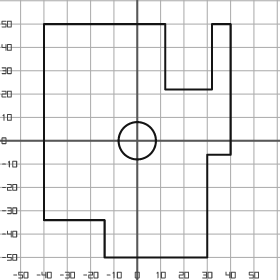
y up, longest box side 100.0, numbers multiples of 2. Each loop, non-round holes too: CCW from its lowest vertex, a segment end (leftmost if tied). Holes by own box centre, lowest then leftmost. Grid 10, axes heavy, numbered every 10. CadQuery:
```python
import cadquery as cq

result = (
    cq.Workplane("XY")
    .moveTo(-14.0, -50.0)
    .lineTo(30.0, -50.0)
    .lineTo(30.0, -6.0)
    .lineTo(40.0, -6.0)
    .lineTo(40.0, 50.0)
    .lineTo(32.0, 50.0)
    .lineTo(32.0, 22.0)
    .lineTo(12.0, 22.0)
    .lineTo(12.0, 50.0)
    .lineTo(-40.0, 50.0)
    .lineTo(-40.0, -34.0)
    .lineTo(-14.0, -34.0)
    .close()
    .moveTo(0.0, 0.0)
    .circle(8.0)
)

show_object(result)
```